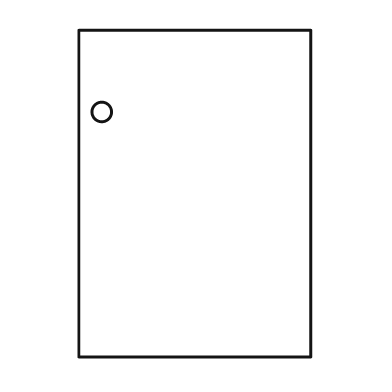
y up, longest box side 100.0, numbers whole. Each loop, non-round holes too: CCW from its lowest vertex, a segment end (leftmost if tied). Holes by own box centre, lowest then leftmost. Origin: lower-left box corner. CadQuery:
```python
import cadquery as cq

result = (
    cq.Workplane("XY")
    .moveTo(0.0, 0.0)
    .lineTo(71.0, 0.0)
    .lineTo(71.0, 100.0)
    .lineTo(0.0, 100.0)
    .close()
    .moveTo(7.0, 75.0)
    .circle(3.0)
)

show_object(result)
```